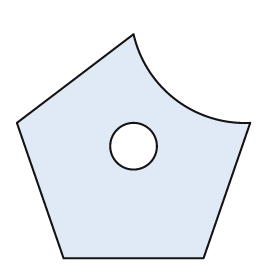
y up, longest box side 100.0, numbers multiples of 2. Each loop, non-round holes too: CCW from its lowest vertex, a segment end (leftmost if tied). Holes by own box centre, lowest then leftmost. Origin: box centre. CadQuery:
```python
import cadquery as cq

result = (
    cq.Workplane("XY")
    .moveTo(-30.0, -48.0)
    .lineTo(30.0, -48.0)
    .lineTo(50.0, 10.0)
    .threePointArc((18.0, 20.0), (0.0, 48.0))
    .lineTo(-50.0, 10.0)
    .close()
    .moveTo(0.0, 0.0)
    .circle(10.0)
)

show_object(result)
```